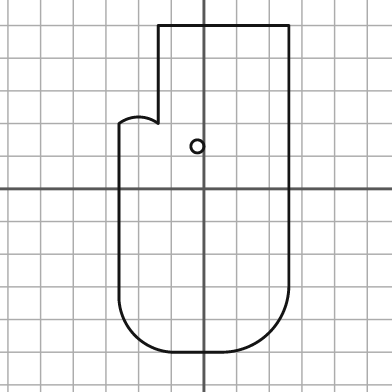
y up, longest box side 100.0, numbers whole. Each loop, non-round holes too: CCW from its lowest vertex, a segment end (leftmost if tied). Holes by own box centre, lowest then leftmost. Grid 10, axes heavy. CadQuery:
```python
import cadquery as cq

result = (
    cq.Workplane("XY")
    .moveTo(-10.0, -50.0)
    .lineTo(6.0, -50.0)
    .threePointArc((20.0, -44.0), (26.0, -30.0))
    .lineTo(26.0, 50.0)
    .lineTo(-14.0, 50.0)
    .lineTo(-14.0, 20.0)
    .threePointArc((-20.0, 22.0), (-26.0, 20.0))
    .lineTo(-26.0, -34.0)
    .threePointArc((-21.0, -45.0), (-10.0, -50.0))
    .close()
    .moveTo(-2.0, 13.0)
    .circle(2.0)
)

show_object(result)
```